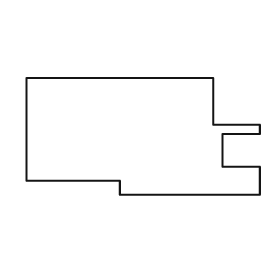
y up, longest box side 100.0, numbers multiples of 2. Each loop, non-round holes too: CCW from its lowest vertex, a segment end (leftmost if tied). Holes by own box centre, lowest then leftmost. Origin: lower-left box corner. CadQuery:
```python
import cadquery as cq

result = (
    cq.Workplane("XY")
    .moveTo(40.0, 0.0)
    .lineTo(100.0, 0.0)
    .lineTo(100.0, 12.0)
    .lineTo(84.0, 12.0)
    .lineTo(84.0, 26.0)
    .lineTo(100.0, 26.0)
    .lineTo(100.0, 30.0)
    .lineTo(80.0, 30.0)
    .lineTo(80.0, 50.0)
    .lineTo(0.0, 50.0)
    .lineTo(0.0, 6.0)
    .lineTo(40.0, 6.0)
    .close()
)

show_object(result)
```